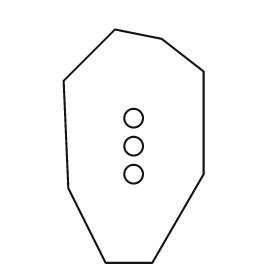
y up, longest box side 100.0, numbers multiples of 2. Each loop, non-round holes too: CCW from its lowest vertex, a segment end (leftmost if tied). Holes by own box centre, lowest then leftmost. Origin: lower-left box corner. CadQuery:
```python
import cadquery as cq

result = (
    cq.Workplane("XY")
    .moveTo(18.0, 0.0)
    .lineTo(38.0, 0.0)
    .lineTo(60.0, 38.0)
    .lineTo(60.0, 82.0)
    .lineTo(42.0, 96.0)
    .lineTo(22.0, 100.0)
    .lineTo(0.0, 78.0)
    .lineTo(2.0, 32.0)
    .close()
    .moveTo(30.0, 38.0)
    .circle(4.0)
    .moveTo(30.0, 50.0)
    .circle(4.0)
    .moveTo(30.0, 62.0)
    .circle(4.0)
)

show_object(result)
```